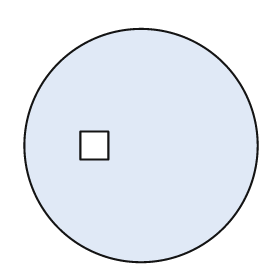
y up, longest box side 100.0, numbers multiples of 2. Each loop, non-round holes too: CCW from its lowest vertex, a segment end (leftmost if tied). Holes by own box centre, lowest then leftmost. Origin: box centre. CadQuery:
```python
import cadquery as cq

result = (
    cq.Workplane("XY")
    .moveTo(0.0, 0.0)
    .circle(50.0)
    .moveTo(-26.0, -6.0)
    .lineTo(-14.0, -6.0)
    .lineTo(-14.0, 6.0)
    .lineTo(-26.0, 6.0)
    .close()
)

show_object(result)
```